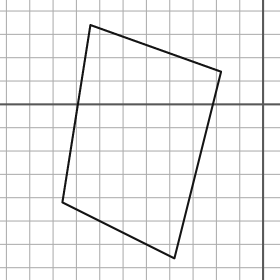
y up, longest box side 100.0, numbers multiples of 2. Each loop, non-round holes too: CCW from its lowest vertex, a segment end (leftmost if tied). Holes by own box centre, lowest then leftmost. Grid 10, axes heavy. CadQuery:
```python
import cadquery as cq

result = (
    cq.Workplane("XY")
    .moveTo(-38.0, -66.0)
    .lineTo(-18.0, 14.0)
    .lineTo(-74.0, 34.0)
    .lineTo(-86.0, -42.0)
    .close()
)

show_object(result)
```